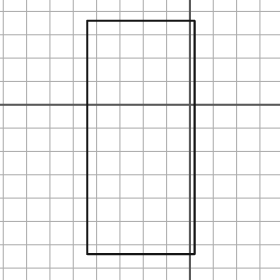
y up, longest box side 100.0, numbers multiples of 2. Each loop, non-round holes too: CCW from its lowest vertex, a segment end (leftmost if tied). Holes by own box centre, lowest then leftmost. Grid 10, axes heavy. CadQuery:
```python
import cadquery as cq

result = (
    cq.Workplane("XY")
    .moveTo(-44.0, -64.0)
    .lineTo(2.0, -64.0)
    .lineTo(2.0, 36.0)
    .lineTo(-44.0, 36.0)
    .close()
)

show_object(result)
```